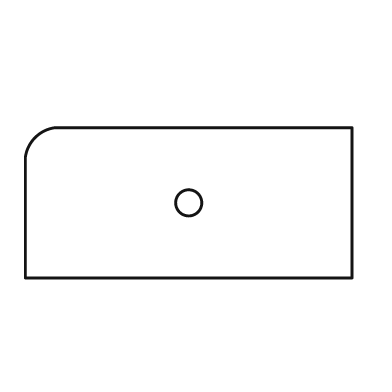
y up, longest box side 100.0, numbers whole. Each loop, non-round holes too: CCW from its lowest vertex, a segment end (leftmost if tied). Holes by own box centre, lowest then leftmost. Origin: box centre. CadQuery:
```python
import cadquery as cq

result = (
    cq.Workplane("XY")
    .moveTo(-50.0, -23.0)
    .lineTo(50.0, -23.0)
    .lineTo(50.0, 23.0)
    .lineTo(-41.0, 23.0)
    .threePointArc((-47.0, 20.0), (-50.0, 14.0))
    .close()
    .moveTo(0.0, 0.0)
    .circle(4.0)
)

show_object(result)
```